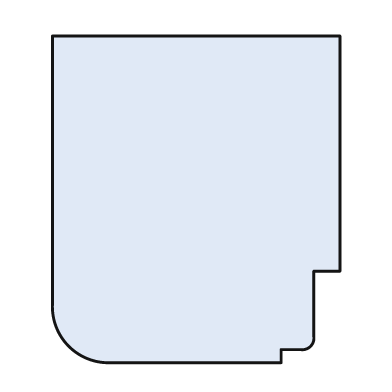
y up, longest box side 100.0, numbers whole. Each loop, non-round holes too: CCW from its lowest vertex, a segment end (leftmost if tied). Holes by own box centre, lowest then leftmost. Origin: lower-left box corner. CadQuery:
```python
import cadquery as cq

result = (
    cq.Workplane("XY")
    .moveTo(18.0, 0.0)
    .lineTo(70.0, 0.0)
    .lineTo(70.0, 4.0)
    .lineTo(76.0, 4.0)
    .threePointArc((79.0, 5.0), (80.0, 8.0))
    .lineTo(80.0, 28.0)
    .lineTo(88.0, 28.0)
    .lineTo(88.0, 100.0)
    .lineTo(0.0, 100.0)
    .lineTo(0.0, 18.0)
    .threePointArc((5.0, 5.0), (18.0, 0.0))
    .close()
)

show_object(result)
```